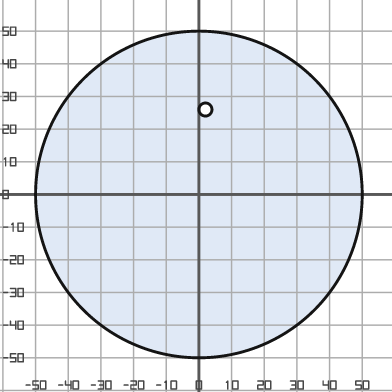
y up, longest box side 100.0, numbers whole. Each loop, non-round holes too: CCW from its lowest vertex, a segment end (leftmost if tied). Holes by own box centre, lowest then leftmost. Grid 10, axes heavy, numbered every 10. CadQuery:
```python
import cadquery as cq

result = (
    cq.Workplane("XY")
    .moveTo(0.0, 0.0)
    .circle(50.0)
    .moveTo(2.0, 26.0)
    .circle(2.0)
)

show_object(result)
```